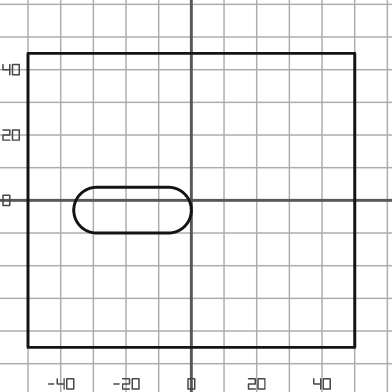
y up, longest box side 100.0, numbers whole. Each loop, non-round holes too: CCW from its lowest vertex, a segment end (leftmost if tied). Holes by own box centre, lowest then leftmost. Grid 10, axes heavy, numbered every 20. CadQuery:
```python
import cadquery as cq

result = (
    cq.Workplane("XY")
    .moveTo(-50.0, -45.0)
    .lineTo(50.0, -45.0)
    .lineTo(50.0, 45.0)
    .lineTo(-50.0, 45.0)
    .close()
    .moveTo(-29.0, -10.0)
    .lineTo(-7.0, -10.0)
    .threePointArc((0.0, -3.0), (-7.0, 4.0))
    .lineTo(-29.0, 4.0)
    .threePointArc((-36.0, -3.0), (-29.0, -10.0))
    .close()
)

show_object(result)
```